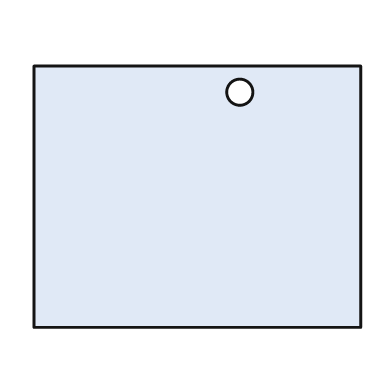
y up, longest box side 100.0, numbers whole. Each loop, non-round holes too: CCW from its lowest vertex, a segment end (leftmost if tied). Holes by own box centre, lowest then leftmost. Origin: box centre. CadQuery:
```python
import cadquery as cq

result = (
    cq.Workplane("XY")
    .moveTo(-50.0, -40.0)
    .lineTo(50.0, -40.0)
    .lineTo(50.0, 40.0)
    .lineTo(-50.0, 40.0)
    .close()
    .moveTo(13.0, 32.0)
    .circle(4.0)
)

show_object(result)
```